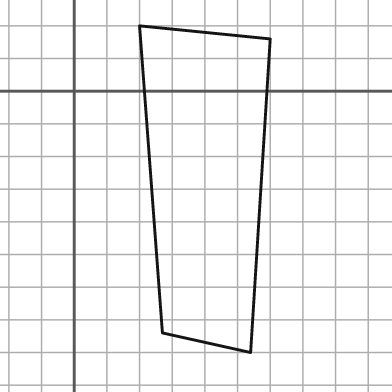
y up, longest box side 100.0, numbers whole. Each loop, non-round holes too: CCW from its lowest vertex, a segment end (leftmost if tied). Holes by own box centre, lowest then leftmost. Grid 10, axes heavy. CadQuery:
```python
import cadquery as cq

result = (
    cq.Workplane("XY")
    .moveTo(54.0, -80.0)
    .lineTo(60.0, 16.0)
    .lineTo(20.0, 20.0)
    .lineTo(27.0, -74.0)
    .close()
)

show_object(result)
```